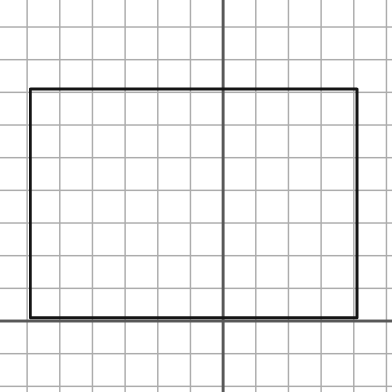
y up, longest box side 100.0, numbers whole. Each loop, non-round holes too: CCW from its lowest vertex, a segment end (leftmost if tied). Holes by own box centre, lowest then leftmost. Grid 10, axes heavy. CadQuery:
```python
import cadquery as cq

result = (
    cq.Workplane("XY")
    .moveTo(-59.0, 1.0)
    .lineTo(41.0, 1.0)
    .lineTo(41.0, 71.0)
    .lineTo(-59.0, 71.0)
    .close()
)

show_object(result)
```